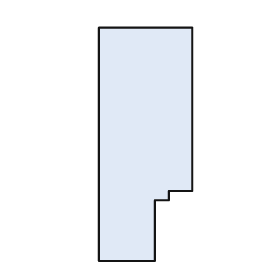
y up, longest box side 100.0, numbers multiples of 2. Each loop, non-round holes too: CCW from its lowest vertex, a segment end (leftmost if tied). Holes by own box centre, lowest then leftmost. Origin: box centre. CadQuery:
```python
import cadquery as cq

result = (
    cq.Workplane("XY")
    .moveTo(-20.0, -50.0)
    .lineTo(4.0, -50.0)
    .lineTo(4.0, -24.0)
    .lineTo(10.0, -24.0)
    .lineTo(10.0, -20.0)
    .lineTo(20.0, -20.0)
    .lineTo(20.0, 50.0)
    .lineTo(-20.0, 50.0)
    .close()
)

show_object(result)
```